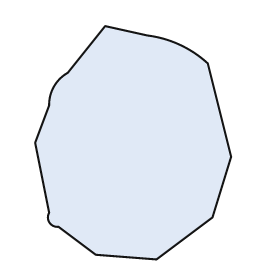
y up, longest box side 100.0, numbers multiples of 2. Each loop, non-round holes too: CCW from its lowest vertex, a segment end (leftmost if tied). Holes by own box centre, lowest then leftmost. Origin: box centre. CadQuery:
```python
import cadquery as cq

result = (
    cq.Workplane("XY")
    .moveTo(10.0, -50.0)
    .lineTo(34.0, -32.0)
    .lineTo(42.0, -6.0)
    .lineTo(32.0, 34.0)
    .threePointArc((20.0, 42.0), (6.0, 46.0))
    .lineTo(-12.0, 50.0)
    .lineTo(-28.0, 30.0)
    .threePointArc((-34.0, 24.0), (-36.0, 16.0))
    .lineTo(-42.0, 0.0)
    .lineTo(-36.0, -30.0)
    .threePointArc((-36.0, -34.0), (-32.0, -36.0))
    .lineTo(-16.0, -48.0)
    .close()
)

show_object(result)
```